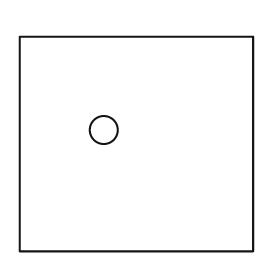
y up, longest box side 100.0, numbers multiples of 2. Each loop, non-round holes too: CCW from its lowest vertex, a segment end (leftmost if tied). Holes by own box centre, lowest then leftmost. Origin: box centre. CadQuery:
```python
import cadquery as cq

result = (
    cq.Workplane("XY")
    .moveTo(-50.0, -46.0)
    .lineTo(50.0, -46.0)
    .lineTo(50.0, 46.0)
    .lineTo(-50.0, 46.0)
    .close()
    .moveTo(-14.0, 6.0)
    .circle(6.0)
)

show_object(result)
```